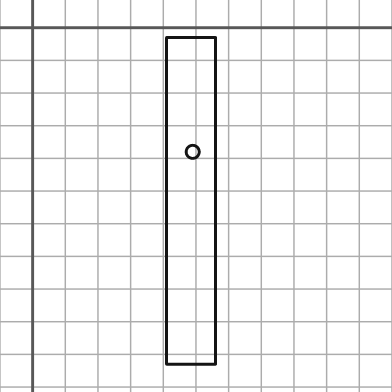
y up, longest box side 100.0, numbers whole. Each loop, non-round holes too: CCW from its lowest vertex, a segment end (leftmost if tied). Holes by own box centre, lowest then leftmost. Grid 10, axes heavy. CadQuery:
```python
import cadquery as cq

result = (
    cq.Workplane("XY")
    .moveTo(41.0, -103.0)
    .lineTo(56.0, -103.0)
    .lineTo(56.0, -3.0)
    .lineTo(41.0, -3.0)
    .close()
    .moveTo(49.0, -38.0)
    .circle(2.0)
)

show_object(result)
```